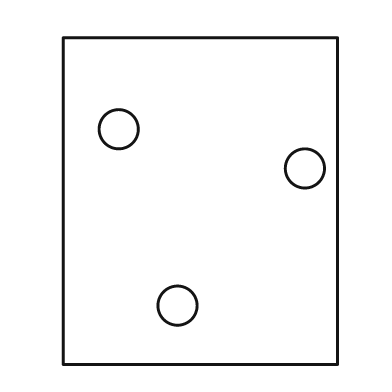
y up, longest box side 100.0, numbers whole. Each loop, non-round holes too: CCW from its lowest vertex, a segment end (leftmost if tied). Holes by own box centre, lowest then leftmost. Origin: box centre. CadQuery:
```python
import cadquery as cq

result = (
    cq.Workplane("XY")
    .moveTo(-42.0, -50.0)
    .lineTo(42.0, -50.0)
    .lineTo(42.0, 50.0)
    .lineTo(-42.0, 50.0)
    .close()
    .moveTo(-7.0, -32.0)
    .circle(6.0)
    .moveTo(32.0, 10.0)
    .circle(6.0)
    .moveTo(-25.0, 22.0)
    .circle(6.0)
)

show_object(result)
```